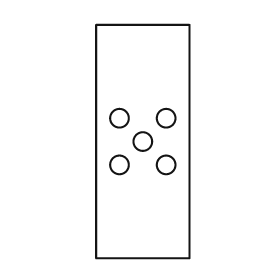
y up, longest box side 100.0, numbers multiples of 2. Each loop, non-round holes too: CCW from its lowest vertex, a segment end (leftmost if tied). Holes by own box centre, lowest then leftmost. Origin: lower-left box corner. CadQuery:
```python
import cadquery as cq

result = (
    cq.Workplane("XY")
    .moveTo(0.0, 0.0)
    .lineTo(40.0, 0.0)
    .lineTo(40.0, 100.0)
    .lineTo(0.0, 100.0)
    .close()
    .moveTo(10.0, 40.0)
    .circle(4.0)
    .moveTo(30.0, 40.0)
    .circle(4.0)
    .moveTo(20.0, 50.0)
    .circle(4.0)
    .moveTo(10.0, 60.0)
    .circle(4.0)
    .moveTo(30.0, 60.0)
    .circle(4.0)
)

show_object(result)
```